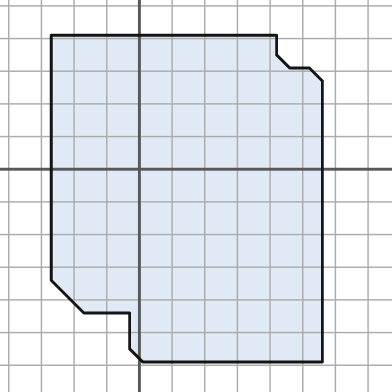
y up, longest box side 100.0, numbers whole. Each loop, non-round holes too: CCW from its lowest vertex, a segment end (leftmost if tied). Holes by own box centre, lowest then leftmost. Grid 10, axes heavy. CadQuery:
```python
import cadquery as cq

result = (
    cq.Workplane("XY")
    .moveTo(1.0, -59.0)
    .lineTo(56.0, -59.0)
    .lineTo(56.0, 27.0)
    .lineTo(52.0, 31.0)
    .lineTo(46.0, 31.0)
    .lineTo(42.0, 35.0)
    .lineTo(42.0, 41.0)
    .lineTo(-27.0, 41.0)
    .lineTo(-27.0, -34.0)
    .lineTo(-17.0, -44.0)
    .lineTo(-3.0, -44.0)
    .lineTo(-3.0, -55.0)
    .close()
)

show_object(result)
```